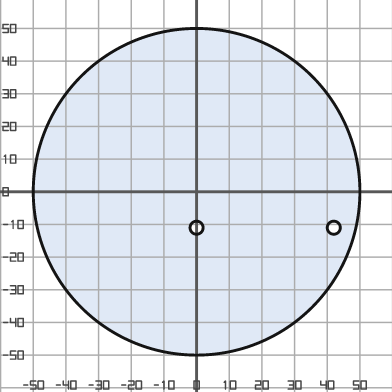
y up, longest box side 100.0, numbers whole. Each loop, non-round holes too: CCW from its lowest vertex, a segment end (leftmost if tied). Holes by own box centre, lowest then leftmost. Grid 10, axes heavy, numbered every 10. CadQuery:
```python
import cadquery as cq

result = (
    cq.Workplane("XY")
    .moveTo(0.0, 0.0)
    .circle(50.0)
    .moveTo(0.0, -11.0)
    .circle(2.0)
    .moveTo(42.0, -11.0)
    .circle(2.0)
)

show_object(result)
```